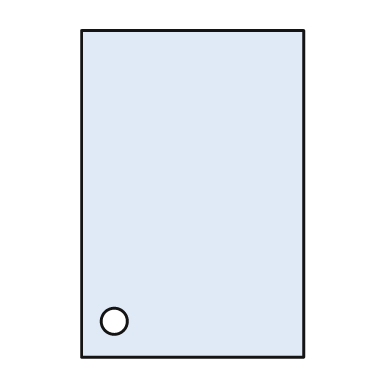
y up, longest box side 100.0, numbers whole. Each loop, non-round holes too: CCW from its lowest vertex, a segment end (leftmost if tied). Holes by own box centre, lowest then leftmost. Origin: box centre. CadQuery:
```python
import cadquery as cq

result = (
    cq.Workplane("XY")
    .moveTo(-34.0, -50.0)
    .lineTo(34.0, -50.0)
    .lineTo(34.0, 50.0)
    .lineTo(-34.0, 50.0)
    .close()
    .moveTo(-24.0, -39.0)
    .circle(4.0)
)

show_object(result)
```